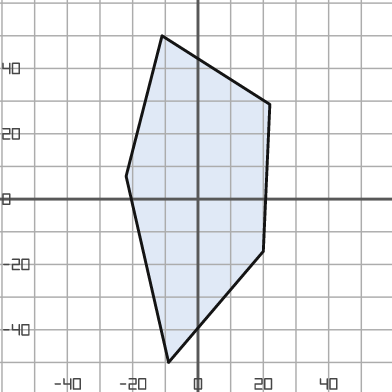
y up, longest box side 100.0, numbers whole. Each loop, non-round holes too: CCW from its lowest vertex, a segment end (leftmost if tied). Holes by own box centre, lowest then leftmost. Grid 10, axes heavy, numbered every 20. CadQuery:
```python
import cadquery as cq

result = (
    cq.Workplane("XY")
    .moveTo(-9.0, -50.0)
    .lineTo(20.0, -16.0)
    .lineTo(22.0, 29.0)
    .lineTo(-11.0, 50.0)
    .lineTo(-22.0, 7.0)
    .close()
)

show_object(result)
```